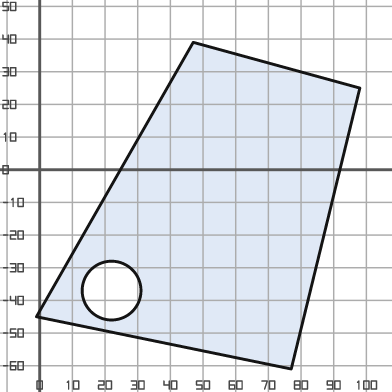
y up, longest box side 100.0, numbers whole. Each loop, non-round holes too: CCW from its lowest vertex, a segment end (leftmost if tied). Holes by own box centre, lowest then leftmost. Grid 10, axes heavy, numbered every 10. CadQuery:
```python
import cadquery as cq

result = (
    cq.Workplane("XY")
    .moveTo(77.0, -61.0)
    .lineTo(98.0, 25.0)
    .lineTo(47.0, 39.0)
    .lineTo(-1.0, -45.0)
    .close()
    .moveTo(22.0, -37.0)
    .circle(9.0)
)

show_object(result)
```